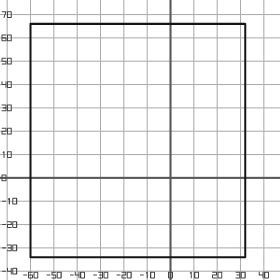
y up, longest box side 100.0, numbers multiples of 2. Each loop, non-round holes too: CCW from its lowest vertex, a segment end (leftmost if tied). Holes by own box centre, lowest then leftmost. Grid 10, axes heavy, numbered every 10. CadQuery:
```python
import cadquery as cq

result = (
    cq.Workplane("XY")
    .moveTo(-60.0, -34.0)
    .lineTo(32.0, -34.0)
    .lineTo(32.0, 66.0)
    .lineTo(-60.0, 66.0)
    .close()
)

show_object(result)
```